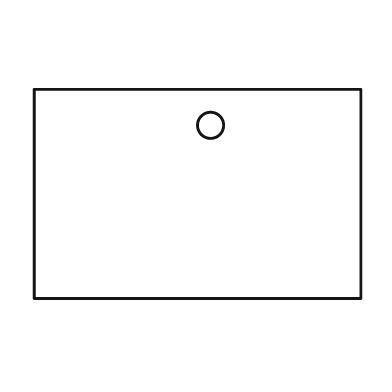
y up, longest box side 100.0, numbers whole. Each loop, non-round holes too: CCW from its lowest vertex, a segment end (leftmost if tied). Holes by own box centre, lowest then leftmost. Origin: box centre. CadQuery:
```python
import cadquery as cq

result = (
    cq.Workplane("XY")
    .moveTo(-50.0, -32.0)
    .lineTo(50.0, -32.0)
    .lineTo(50.0, 32.0)
    .lineTo(-50.0, 32.0)
    .close()
    .moveTo(4.0, 21.0)
    .circle(4.0)
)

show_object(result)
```